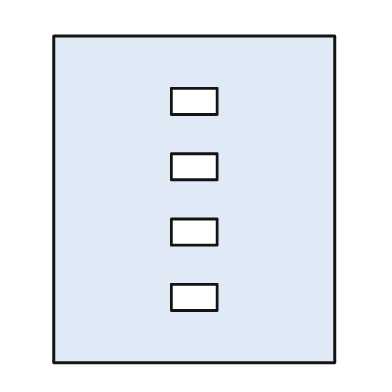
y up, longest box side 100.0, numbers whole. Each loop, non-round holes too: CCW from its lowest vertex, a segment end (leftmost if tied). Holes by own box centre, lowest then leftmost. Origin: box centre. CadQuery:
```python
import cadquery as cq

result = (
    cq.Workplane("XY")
    .moveTo(-43.0, -50.0)
    .lineTo(43.0, -50.0)
    .lineTo(43.0, 50.0)
    .lineTo(-43.0, 50.0)
    .close()
    .moveTo(-7.0, -34.0)
    .lineTo(7.0, -34.0)
    .lineTo(7.0, -26.0)
    .lineTo(-7.0, -26.0)
    .close()
    .moveTo(-7.0, -14.0)
    .lineTo(7.0, -14.0)
    .lineTo(7.0, -6.0)
    .lineTo(-7.0, -6.0)
    .close()
    .moveTo(-7.0, 6.0)
    .lineTo(7.0, 6.0)
    .lineTo(7.0, 14.0)
    .lineTo(-7.0, 14.0)
    .close()
    .moveTo(-7.0, 26.0)
    .lineTo(7.0, 26.0)
    .lineTo(7.0, 34.0)
    .lineTo(-7.0, 34.0)
    .close()
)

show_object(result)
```